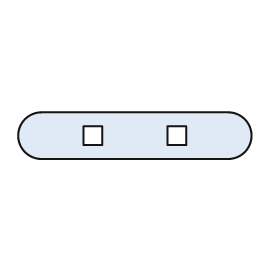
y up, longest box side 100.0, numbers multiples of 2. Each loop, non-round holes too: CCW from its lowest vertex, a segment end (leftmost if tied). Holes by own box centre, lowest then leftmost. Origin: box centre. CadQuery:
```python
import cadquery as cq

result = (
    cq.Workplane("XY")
    .moveTo(-40.0, -10.0)
    .lineTo(40.0, -10.0)
    .threePointArc((50.0, 0.0), (40.0, 10.0))
    .lineTo(-40.0, 10.0)
    .threePointArc((-50.0, 0.0), (-40.0, -10.0))
    .close()
    .moveTo(-22.0, -4.0)
    .lineTo(-14.0, -4.0)
    .lineTo(-14.0, 4.0)
    .lineTo(-22.0, 4.0)
    .close()
    .moveTo(14.0, -4.0)
    .lineTo(22.0, -4.0)
    .lineTo(22.0, 4.0)
    .lineTo(14.0, 4.0)
    .close()
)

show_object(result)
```